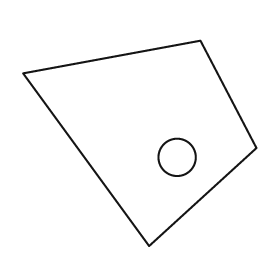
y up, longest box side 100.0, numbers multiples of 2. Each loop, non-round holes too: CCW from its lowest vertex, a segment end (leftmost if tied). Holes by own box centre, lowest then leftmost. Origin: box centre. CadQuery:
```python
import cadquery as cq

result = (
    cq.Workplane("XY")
    .moveTo(4.0, -44.0)
    .lineTo(50.0, -2.0)
    .lineTo(26.0, 44.0)
    .lineTo(-50.0, 30.0)
    .close()
    .moveTo(16.0, -6.0)
    .circle(8.0)
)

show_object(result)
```